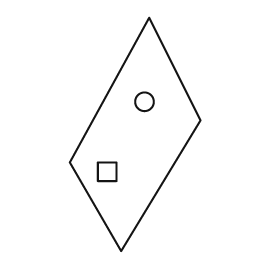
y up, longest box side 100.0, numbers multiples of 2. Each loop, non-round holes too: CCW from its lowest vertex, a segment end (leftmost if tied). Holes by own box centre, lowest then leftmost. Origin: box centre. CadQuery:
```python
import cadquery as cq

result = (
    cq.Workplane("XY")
    .moveTo(-6.0, -50.0)
    .lineTo(28.0, 6.0)
    .lineTo(6.0, 50.0)
    .lineTo(-28.0, -12.0)
    .close()
    .moveTo(-16.0, -20.0)
    .lineTo(-8.0, -20.0)
    .lineTo(-8.0, -12.0)
    .lineTo(-16.0, -12.0)
    .close()
    .moveTo(4.0, 14.0)
    .circle(4.0)
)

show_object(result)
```